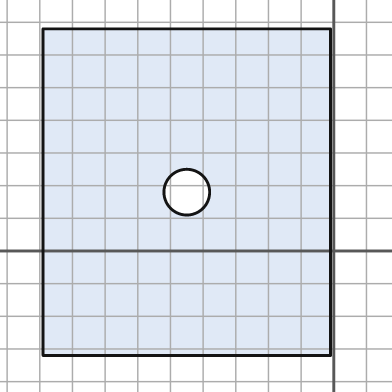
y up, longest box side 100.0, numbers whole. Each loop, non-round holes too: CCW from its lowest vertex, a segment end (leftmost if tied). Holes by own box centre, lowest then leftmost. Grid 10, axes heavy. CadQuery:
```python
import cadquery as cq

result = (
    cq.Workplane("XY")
    .moveTo(-89.0, -32.0)
    .lineTo(-1.0, -32.0)
    .lineTo(-1.0, 68.0)
    .lineTo(-89.0, 68.0)
    .close()
    .moveTo(-45.0, 18.0)
    .circle(7.0)
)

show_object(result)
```